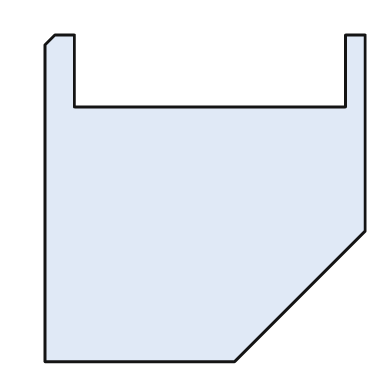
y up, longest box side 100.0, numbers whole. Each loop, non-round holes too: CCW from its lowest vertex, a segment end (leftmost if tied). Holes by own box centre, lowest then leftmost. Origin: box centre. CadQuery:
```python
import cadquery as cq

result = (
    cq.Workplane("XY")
    .moveTo(-49.0, -50.0)
    .lineTo(9.0, -50.0)
    .lineTo(49.0, -10.0)
    .lineTo(49.0, 50.0)
    .lineTo(43.0, 50.0)
    .lineTo(43.0, 28.0)
    .lineTo(-40.0, 28.0)
    .lineTo(-40.0, 50.0)
    .lineTo(-46.0, 50.0)
    .lineTo(-49.0, 47.0)
    .close()
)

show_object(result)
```